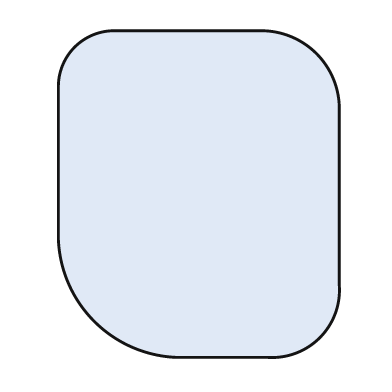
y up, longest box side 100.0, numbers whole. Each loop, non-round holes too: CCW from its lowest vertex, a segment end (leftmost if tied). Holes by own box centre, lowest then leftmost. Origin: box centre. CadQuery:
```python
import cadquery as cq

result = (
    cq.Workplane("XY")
    .moveTo(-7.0, -50.0)
    .lineTo(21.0, -50.0)
    .threePointArc((37.0, -44.0), (43.0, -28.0))
    .lineTo(43.0, 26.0)
    .threePointArc((36.0, 43.0), (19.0, 50.0))
    .lineTo(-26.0, 50.0)
    .threePointArc((-38.0, 45.0), (-43.0, 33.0))
    .lineTo(-43.0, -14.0)
    .threePointArc((-32.0, -39.0), (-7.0, -50.0))
    .close()
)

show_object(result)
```